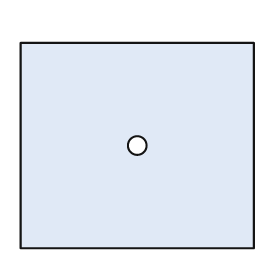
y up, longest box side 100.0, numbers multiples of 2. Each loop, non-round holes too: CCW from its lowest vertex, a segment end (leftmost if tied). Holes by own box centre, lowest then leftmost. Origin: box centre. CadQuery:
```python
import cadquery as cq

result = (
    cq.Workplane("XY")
    .moveTo(-50.0, -44.0)
    .lineTo(50.0, -44.0)
    .lineTo(50.0, 44.0)
    .lineTo(-50.0, 44.0)
    .close()
    .moveTo(0.0, 0.0)
    .circle(4.0)
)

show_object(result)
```